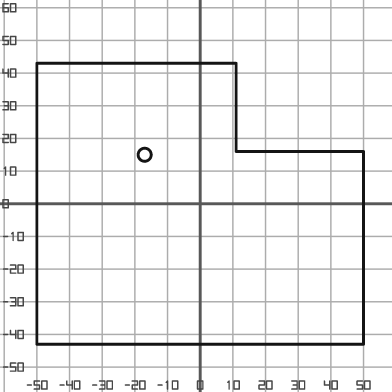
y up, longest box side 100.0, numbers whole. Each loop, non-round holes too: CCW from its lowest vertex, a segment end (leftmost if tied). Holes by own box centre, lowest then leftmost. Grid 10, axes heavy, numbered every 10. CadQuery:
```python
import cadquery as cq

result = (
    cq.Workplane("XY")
    .moveTo(-50.0, -43.0)
    .lineTo(50.0, -43.0)
    .lineTo(50.0, 16.0)
    .lineTo(11.0, 16.0)
    .lineTo(11.0, 43.0)
    .lineTo(-50.0, 43.0)
    .close()
    .moveTo(-17.0, 15.0)
    .circle(2.0)
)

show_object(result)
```